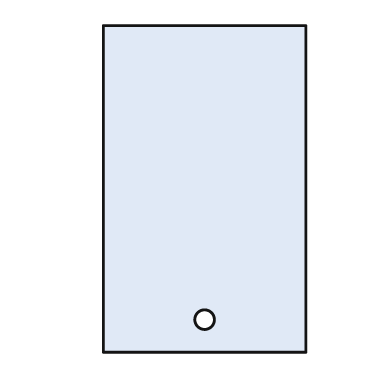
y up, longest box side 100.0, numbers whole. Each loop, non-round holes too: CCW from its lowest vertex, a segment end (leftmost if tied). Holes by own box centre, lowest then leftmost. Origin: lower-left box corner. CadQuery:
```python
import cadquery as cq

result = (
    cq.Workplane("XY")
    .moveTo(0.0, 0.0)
    .lineTo(62.0, 0.0)
    .lineTo(62.0, 100.0)
    .lineTo(0.0, 100.0)
    .close()
    .moveTo(31.0, 10.0)
    .circle(3.0)
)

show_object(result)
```